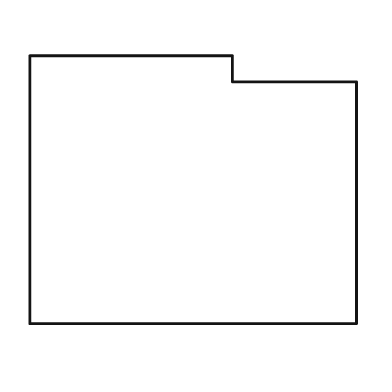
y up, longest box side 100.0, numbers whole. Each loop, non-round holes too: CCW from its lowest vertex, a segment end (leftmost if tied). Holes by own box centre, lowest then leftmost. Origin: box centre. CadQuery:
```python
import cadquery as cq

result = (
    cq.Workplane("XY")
    .moveTo(-50.0, -41.0)
    .lineTo(50.0, -41.0)
    .lineTo(50.0, 33.0)
    .lineTo(12.0, 33.0)
    .lineTo(12.0, 41.0)
    .lineTo(-50.0, 41.0)
    .close()
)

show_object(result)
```